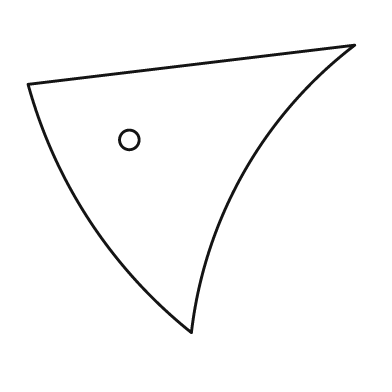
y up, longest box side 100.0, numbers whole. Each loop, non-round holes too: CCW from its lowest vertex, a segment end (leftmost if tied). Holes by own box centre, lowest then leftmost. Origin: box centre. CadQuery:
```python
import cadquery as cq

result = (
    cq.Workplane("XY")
    .moveTo(0.0, -44.0)
    .threePointArc((16.0, 5.0), (50.0, 44.0))
    .lineTo(-50.0, 32.0)
    .threePointArc((-31.0, -10.0), (0.0, -44.0))
    .close()
    .moveTo(-19.0, 15.0)
    .circle(3.0)
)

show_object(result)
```